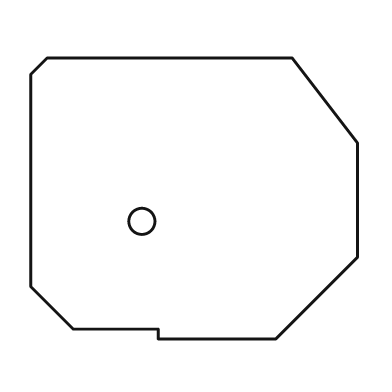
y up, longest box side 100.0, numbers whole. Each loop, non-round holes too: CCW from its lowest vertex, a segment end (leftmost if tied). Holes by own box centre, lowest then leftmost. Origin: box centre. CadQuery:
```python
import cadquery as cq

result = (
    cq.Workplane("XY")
    .moveTo(-11.0, -43.0)
    .lineTo(25.0, -43.0)
    .lineTo(50.0, -18.0)
    .lineTo(50.0, 17.0)
    .lineTo(30.0, 43.0)
    .lineTo(-45.0, 43.0)
    .lineTo(-50.0, 38.0)
    .lineTo(-50.0, -27.0)
    .lineTo(-37.0, -40.0)
    .lineTo(-11.0, -40.0)
    .close()
    .moveTo(-16.0, -7.0)
    .circle(4.0)
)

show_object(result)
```